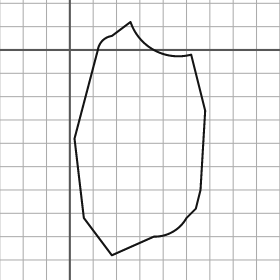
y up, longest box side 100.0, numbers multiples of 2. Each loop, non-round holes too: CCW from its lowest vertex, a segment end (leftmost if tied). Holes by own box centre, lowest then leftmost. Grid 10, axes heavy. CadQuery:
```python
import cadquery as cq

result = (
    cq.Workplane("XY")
    .moveTo(18.0, -88.0)
    .lineTo(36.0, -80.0)
    .threePointArc((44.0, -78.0), (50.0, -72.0))
    .lineTo(54.0, -68.0)
    .lineTo(56.0, -60.0)
    .lineTo(58.0, -26.0)
    .lineTo(52.0, -2.0)
    .threePointArc((36.0, 0.0), (26.0, 12.0))
    .lineTo(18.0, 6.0)
    .threePointArc((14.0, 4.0), (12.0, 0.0))
    .lineTo(2.0, -38.0)
    .lineTo(6.0, -72.0)
    .close()
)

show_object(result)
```